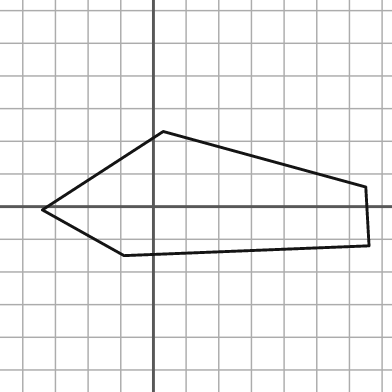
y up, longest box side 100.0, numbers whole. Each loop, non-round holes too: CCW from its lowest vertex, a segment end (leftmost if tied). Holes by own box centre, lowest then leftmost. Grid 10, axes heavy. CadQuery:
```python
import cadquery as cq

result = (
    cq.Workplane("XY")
    .moveTo(-9.0, -15.0)
    .lineTo(66.0, -12.0)
    .lineTo(65.0, 6.0)
    .lineTo(3.0, 23.0)
    .lineTo(-34.0, -1.0)
    .close()
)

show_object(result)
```